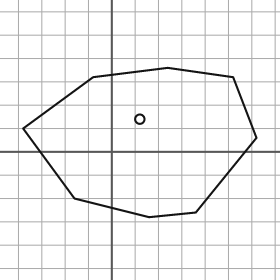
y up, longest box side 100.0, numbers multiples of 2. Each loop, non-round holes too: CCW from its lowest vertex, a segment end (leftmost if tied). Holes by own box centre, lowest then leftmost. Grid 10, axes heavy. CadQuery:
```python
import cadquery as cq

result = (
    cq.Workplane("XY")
    .moveTo(16.0, -28.0)
    .lineTo(36.0, -26.0)
    .lineTo(62.0, 6.0)
    .lineTo(52.0, 32.0)
    .lineTo(24.0, 36.0)
    .lineTo(-8.0, 32.0)
    .lineTo(-38.0, 10.0)
    .lineTo(-16.0, -20.0)
    .close()
    .moveTo(12.0, 14.0)
    .circle(2.0)
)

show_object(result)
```